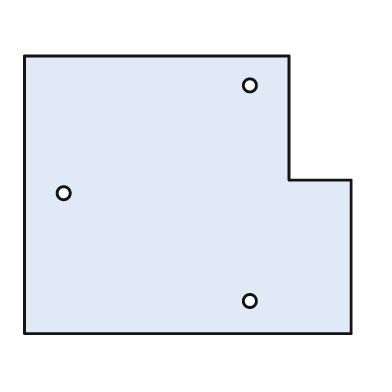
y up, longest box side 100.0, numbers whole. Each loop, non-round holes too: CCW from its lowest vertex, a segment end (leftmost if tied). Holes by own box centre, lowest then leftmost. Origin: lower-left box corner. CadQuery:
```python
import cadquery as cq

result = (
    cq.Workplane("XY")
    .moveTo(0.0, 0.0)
    .lineTo(100.0, 0.0)
    .lineTo(100.0, 47.0)
    .lineTo(81.0, 47.0)
    .lineTo(81.0, 85.0)
    .lineTo(0.0, 85.0)
    .close()
    .moveTo(69.0, 10.0)
    .circle(2.0)
    .moveTo(12.0, 43.0)
    .circle(2.0)
    .moveTo(69.0, 76.0)
    .circle(2.0)
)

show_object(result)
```